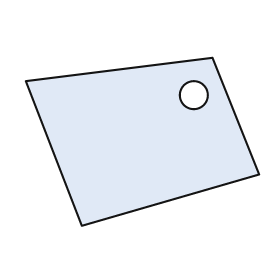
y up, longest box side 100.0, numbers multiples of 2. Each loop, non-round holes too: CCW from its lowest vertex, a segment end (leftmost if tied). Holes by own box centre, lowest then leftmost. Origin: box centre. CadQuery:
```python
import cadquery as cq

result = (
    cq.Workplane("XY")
    .moveTo(-26.0, -36.0)
    .lineTo(50.0, -14.0)
    .lineTo(30.0, 36.0)
    .lineTo(-50.0, 26.0)
    .close()
    .moveTo(22.0, 20.0)
    .circle(6.0)
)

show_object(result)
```